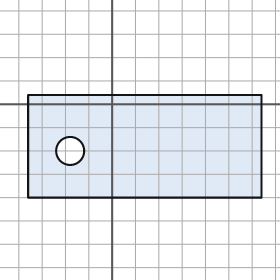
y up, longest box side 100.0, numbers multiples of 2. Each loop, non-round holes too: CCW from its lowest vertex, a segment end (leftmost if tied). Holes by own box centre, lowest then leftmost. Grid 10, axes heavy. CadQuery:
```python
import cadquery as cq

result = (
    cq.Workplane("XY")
    .moveTo(-36.0, -40.0)
    .lineTo(64.0, -40.0)
    .lineTo(64.0, 4.0)
    .lineTo(-36.0, 4.0)
    .close()
    .moveTo(-18.0, -20.0)
    .circle(6.0)
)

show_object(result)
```